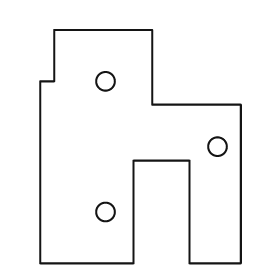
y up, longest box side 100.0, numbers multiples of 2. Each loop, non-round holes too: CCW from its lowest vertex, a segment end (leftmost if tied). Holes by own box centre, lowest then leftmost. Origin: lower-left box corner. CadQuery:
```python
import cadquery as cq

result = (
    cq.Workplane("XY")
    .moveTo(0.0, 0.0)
    .lineTo(40.0, 0.0)
    .lineTo(40.0, 44.0)
    .lineTo(64.0, 44.0)
    .lineTo(64.0, 0.0)
    .lineTo(86.0, 0.0)
    .lineTo(86.0, 68.0)
    .lineTo(48.0, 68.0)
    .lineTo(48.0, 100.0)
    .lineTo(6.0, 100.0)
    .lineTo(6.0, 78.0)
    .lineTo(0.0, 78.0)
    .close()
    .moveTo(28.0, 22.0)
    .circle(4.0)
    .moveTo(76.0, 50.0)
    .circle(4.0)
    .moveTo(28.0, 78.0)
    .circle(4.0)
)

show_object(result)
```